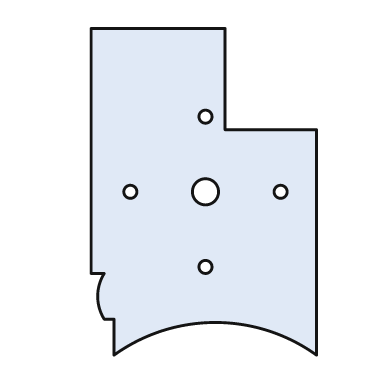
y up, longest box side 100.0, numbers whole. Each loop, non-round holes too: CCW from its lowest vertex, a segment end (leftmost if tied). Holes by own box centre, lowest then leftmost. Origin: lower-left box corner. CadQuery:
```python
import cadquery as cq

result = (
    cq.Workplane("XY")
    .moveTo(7.0, 0.0)
    .threePointArc((38.0, 10.0), (69.0, 0.0))
    .lineTo(69.0, 69.0)
    .lineTo(41.0, 69.0)
    .lineTo(41.0, 100.0)
    .lineTo(0.0, 100.0)
    .lineTo(0.0, 25.0)
    .lineTo(4.0, 25.0)
    .threePointArc((2.0, 18.0), (4.0, 11.0))
    .lineTo(7.0, 11.0)
    .close()
    .moveTo(35.0, 27.0)
    .circle(2.0)
    .moveTo(12.0, 50.0)
    .circle(2.0)
    .moveTo(35.0, 50.0)
    .circle(4.0)
    .moveTo(58.0, 50.0)
    .circle(2.0)
    .moveTo(35.0, 73.0)
    .circle(2.0)
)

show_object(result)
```